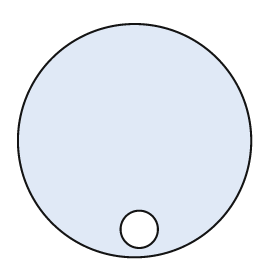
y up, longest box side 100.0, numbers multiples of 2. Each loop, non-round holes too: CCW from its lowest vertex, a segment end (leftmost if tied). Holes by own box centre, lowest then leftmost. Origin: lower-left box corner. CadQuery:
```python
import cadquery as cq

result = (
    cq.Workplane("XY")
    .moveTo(50.0, 50.0)
    .circle(50.0)
    .moveTo(52.0, 12.0)
    .circle(8.0)
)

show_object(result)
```